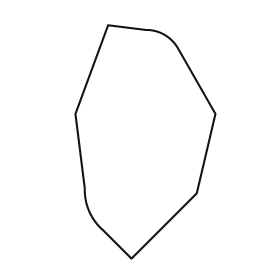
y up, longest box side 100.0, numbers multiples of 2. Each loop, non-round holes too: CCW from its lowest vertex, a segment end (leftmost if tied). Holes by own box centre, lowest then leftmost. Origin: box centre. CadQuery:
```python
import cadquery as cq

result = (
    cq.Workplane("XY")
    .moveTo(-6.0, -50.0)
    .lineTo(22.0, -22.0)
    .lineTo(30.0, 12.0)
    .lineTo(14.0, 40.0)
    .threePointArc((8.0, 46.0), (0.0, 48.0))
    .lineTo(-16.0, 50.0)
    .lineTo(-30.0, 12.0)
    .lineTo(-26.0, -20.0)
    .threePointArc((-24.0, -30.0), (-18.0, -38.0))
    .close()
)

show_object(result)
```